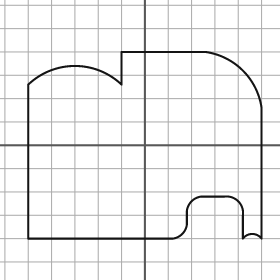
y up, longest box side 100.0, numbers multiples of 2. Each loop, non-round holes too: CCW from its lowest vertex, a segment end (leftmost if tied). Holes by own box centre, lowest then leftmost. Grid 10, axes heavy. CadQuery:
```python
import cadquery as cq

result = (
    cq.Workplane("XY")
    .moveTo(-50.0, -40.0)
    .lineTo(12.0, -40.0)
    .threePointArc((16.0, -38.0), (18.0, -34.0))
    .lineTo(18.0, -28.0)
    .threePointArc((20.0, -24.0), (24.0, -22.0))
    .lineTo(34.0, -22.0)
    .threePointArc((40.0, -24.0), (42.0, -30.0))
    .lineTo(42.0, -40.0)
    .threePointArc((46.0, -38.0), (50.0, -40.0))
    .lineTo(50.0, 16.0)
    .threePointArc((42.0, 32.0), (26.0, 40.0))
    .lineTo(-10.0, 40.0)
    .lineTo(-10.0, 26.0)
    .threePointArc((-30.0, 34.0), (-50.0, 26.0))
    .close()
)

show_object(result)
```